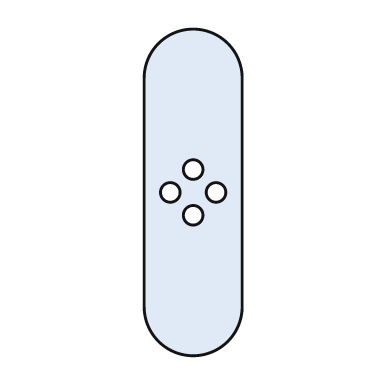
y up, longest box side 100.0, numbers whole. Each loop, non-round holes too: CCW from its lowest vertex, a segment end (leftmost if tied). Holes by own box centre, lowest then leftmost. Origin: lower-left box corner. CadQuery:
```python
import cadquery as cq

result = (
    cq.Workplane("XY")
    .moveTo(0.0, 15.0)
    .threePointArc((15.0, 0.0), (30.0, 15.0))
    .lineTo(30.0, 85.0)
    .threePointArc((15.0, 100.0), (0.0, 85.0))
    .close()
    .moveTo(15.0, 43.0)
    .circle(3.0)
    .moveTo(8.0, 50.0)
    .circle(3.0)
    .moveTo(22.0, 50.0)
    .circle(3.0)
    .moveTo(15.0, 57.0)
    .circle(3.0)
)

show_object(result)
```